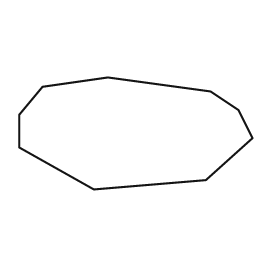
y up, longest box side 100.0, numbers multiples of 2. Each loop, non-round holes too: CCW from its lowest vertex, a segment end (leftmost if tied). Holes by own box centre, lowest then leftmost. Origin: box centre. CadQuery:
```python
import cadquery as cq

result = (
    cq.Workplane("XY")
    .moveTo(-18.0, -24.0)
    .lineTo(30.0, -20.0)
    .lineTo(50.0, -2.0)
    .lineTo(44.0, 10.0)
    .lineTo(32.0, 18.0)
    .lineTo(-12.0, 24.0)
    .lineTo(-40.0, 20.0)
    .lineTo(-50.0, 8.0)
    .lineTo(-50.0, -6.0)
    .close()
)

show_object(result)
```